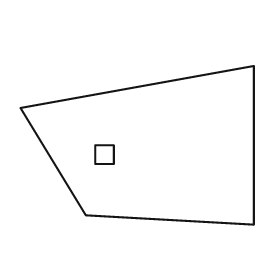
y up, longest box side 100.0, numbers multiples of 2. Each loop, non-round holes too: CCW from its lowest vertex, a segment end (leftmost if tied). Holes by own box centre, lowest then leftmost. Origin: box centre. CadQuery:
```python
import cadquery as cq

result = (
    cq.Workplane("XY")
    .moveTo(50.0, -34.0)
    .lineTo(50.0, 34.0)
    .lineTo(-50.0, 16.0)
    .lineTo(-22.0, -30.0)
    .close()
    .moveTo(-18.0, -8.0)
    .lineTo(-10.0, -8.0)
    .lineTo(-10.0, 0.0)
    .lineTo(-18.0, 0.0)
    .close()
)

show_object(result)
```